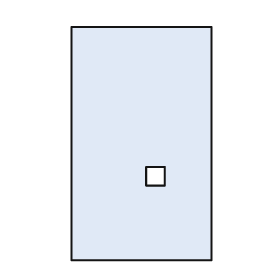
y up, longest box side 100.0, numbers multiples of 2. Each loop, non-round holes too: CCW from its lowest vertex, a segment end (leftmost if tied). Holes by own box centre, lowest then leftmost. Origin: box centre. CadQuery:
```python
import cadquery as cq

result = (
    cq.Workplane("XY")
    .moveTo(-30.0, -50.0)
    .lineTo(30.0, -50.0)
    .lineTo(30.0, 50.0)
    .lineTo(-30.0, 50.0)
    .close()
    .moveTo(2.0, -18.0)
    .lineTo(10.0, -18.0)
    .lineTo(10.0, -10.0)
    .lineTo(2.0, -10.0)
    .close()
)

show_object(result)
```